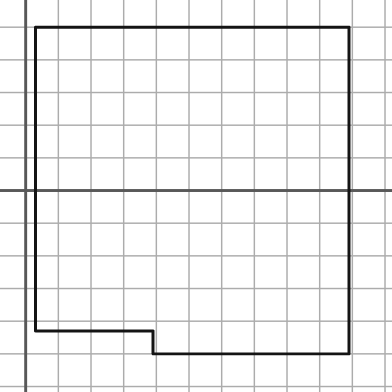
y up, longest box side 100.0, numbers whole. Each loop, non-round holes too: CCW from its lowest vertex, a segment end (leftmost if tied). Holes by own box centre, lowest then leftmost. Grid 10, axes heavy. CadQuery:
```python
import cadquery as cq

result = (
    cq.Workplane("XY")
    .moveTo(39.0, -50.0)
    .lineTo(99.0, -50.0)
    .lineTo(99.0, 50.0)
    .lineTo(3.0, 50.0)
    .lineTo(3.0, -43.0)
    .lineTo(39.0, -43.0)
    .close()
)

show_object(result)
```